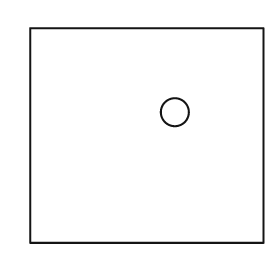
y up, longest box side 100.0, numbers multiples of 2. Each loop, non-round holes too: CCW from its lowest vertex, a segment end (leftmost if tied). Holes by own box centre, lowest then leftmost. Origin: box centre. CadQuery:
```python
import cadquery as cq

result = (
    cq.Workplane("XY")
    .moveTo(-50.0, -46.0)
    .lineTo(50.0, -46.0)
    .lineTo(50.0, 46.0)
    .lineTo(-50.0, 46.0)
    .close()
    .moveTo(12.0, 10.0)
    .circle(6.0)
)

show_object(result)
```